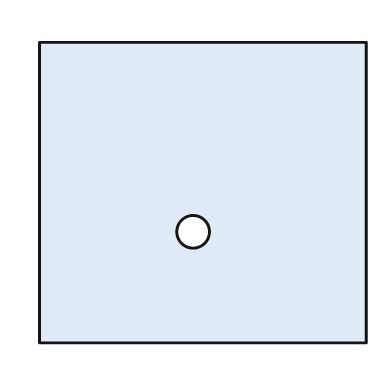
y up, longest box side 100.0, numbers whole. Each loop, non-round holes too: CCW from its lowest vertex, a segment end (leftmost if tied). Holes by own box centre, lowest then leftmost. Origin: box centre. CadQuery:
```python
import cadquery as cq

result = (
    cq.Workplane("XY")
    .moveTo(-50.0, -46.0)
    .lineTo(50.0, -46.0)
    .lineTo(50.0, 46.0)
    .lineTo(-50.0, 46.0)
    .close()
    .moveTo(-3.0, -12.0)
    .circle(5.0)
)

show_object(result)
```